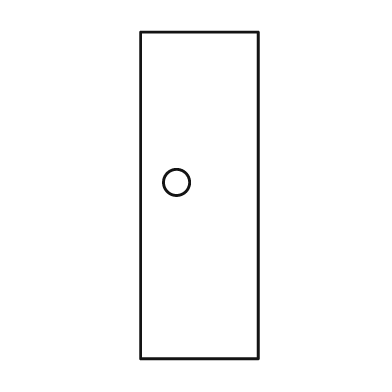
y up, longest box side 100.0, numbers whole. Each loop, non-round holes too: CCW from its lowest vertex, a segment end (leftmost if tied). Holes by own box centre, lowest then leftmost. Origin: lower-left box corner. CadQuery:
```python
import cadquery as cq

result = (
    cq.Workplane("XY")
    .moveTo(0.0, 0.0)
    .lineTo(36.0, 0.0)
    .lineTo(36.0, 100.0)
    .lineTo(0.0, 100.0)
    .close()
    .moveTo(11.0, 54.0)
    .circle(4.0)
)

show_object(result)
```